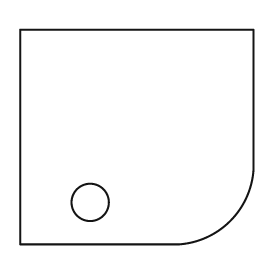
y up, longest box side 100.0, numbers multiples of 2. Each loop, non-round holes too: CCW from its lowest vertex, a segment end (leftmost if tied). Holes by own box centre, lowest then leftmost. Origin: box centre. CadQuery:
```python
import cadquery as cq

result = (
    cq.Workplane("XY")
    .moveTo(-50.0, -46.0)
    .lineTo(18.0, -46.0)
    .threePointArc((40.0, -36.0), (50.0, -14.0))
    .lineTo(50.0, 46.0)
    .lineTo(-50.0, 46.0)
    .close()
    .moveTo(-20.0, -28.0)
    .circle(8.0)
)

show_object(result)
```